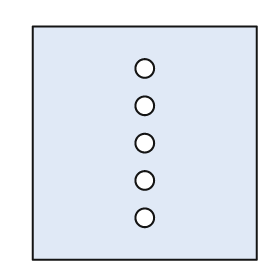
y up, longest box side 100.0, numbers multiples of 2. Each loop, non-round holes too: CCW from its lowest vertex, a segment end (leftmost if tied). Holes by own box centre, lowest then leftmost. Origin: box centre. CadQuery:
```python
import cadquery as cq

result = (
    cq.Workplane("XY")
    .moveTo(-48.0, -50.0)
    .lineTo(48.0, -50.0)
    .lineTo(48.0, 50.0)
    .lineTo(-48.0, 50.0)
    .close()
    .moveTo(0.0, -32.0)
    .circle(4.0)
    .moveTo(0.0, -16.0)
    .circle(4.0)
    .moveTo(0.0, 0.0)
    .circle(4.0)
    .moveTo(0.0, 16.0)
    .circle(4.0)
    .moveTo(0.0, 32.0)
    .circle(4.0)
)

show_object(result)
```